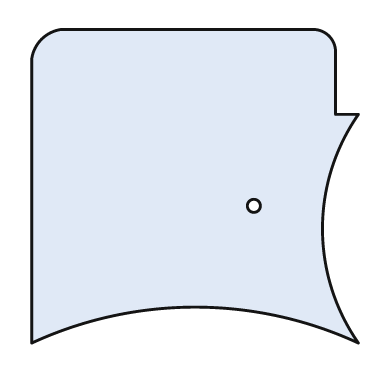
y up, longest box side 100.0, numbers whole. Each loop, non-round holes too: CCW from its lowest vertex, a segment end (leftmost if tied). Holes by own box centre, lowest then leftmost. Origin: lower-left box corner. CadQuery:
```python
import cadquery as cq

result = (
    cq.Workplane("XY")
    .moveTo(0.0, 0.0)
    .threePointArc((50.0, 11.0), (100.0, 0.0))
    .threePointArc((89.0, 35.0), (100.0, 70.0))
    .lineTo(93.0, 70.0)
    .lineTo(93.0, 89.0)
    .threePointArc((91.0, 94.0), (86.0, 96.0))
    .lineTo(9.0, 96.0)
    .threePointArc((3.0, 93.0), (0.0, 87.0))
    .close()
    .moveTo(68.0, 42.0)
    .circle(2.0)
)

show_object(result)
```